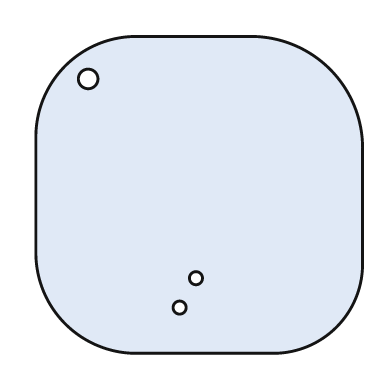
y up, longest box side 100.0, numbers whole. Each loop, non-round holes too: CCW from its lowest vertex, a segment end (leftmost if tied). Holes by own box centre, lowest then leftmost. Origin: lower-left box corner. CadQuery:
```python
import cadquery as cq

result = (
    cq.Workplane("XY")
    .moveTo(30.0, 0.0)
    .lineTo(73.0, 0.0)
    .threePointArc((92.0, 8.0), (100.0, 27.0))
    .lineTo(100.0, 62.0)
    .threePointArc((90.0, 87.0), (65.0, 97.0))
    .lineTo(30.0, 97.0)
    .threePointArc((9.0, 88.0), (0.0, 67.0))
    .lineTo(0.0, 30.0)
    .threePointArc((9.0, 9.0), (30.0, 0.0))
    .close()
    .moveTo(44.0, 14.0)
    .circle(2.0)
    .moveTo(49.0, 23.0)
    .circle(2.0)
    .moveTo(16.0, 84.0)
    .circle(3.0)
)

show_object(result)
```